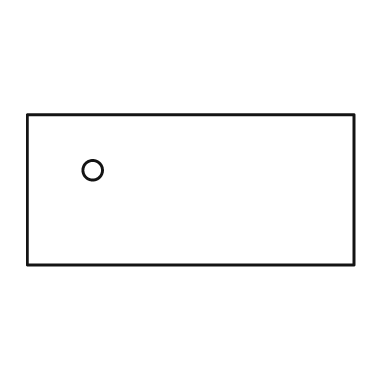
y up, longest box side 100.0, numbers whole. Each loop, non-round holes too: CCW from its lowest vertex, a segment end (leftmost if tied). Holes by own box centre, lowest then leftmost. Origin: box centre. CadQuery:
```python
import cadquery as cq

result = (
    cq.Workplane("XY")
    .moveTo(-50.0, -23.0)
    .lineTo(50.0, -23.0)
    .lineTo(50.0, 23.0)
    .lineTo(-50.0, 23.0)
    .close()
    .moveTo(-30.0, 6.0)
    .circle(3.0)
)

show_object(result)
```